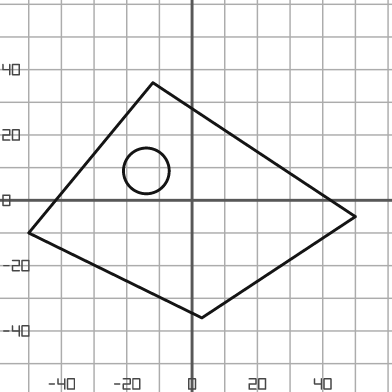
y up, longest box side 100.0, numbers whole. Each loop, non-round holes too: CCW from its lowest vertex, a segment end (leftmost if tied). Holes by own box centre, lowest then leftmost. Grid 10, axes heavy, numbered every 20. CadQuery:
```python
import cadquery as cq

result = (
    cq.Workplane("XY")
    .moveTo(3.0, -36.0)
    .lineTo(50.0, -5.0)
    .lineTo(-12.0, 36.0)
    .lineTo(-50.0, -10.0)
    .close()
    .moveTo(-14.0, 9.0)
    .circle(7.0)
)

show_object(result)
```